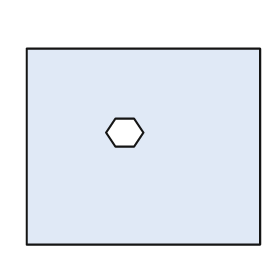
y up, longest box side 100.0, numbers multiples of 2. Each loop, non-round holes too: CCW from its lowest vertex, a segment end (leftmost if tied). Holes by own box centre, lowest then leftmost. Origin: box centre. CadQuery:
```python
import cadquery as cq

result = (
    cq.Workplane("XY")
    .moveTo(-50.0, -42.0)
    .lineTo(50.0, -42.0)
    .lineTo(50.0, 42.0)
    .lineTo(-50.0, 42.0)
    .close()
    .moveTo(-12.0, 0.0)
    .lineTo(-4.0, 0.0)
    .lineTo(0.0, 6.0)
    .lineTo(-4.0, 12.0)
    .lineTo(-12.0, 12.0)
    .lineTo(-16.0, 6.0)
    .close()
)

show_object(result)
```